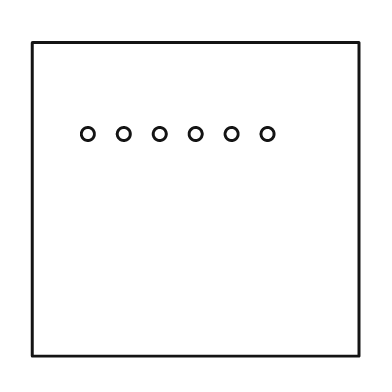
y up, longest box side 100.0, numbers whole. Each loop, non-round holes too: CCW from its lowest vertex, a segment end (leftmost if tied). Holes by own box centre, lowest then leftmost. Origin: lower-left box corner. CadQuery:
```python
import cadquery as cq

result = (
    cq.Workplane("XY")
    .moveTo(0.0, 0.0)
    .lineTo(100.0, 0.0)
    .lineTo(100.0, 96.0)
    .lineTo(0.0, 96.0)
    .close()
    .moveTo(17.0, 68.0)
    .circle(2.0)
    .moveTo(28.0, 68.0)
    .circle(2.0)
    .moveTo(39.0, 68.0)
    .circle(2.0)
    .moveTo(50.0, 68.0)
    .circle(2.0)
    .moveTo(61.0, 68.0)
    .circle(2.0)
    .moveTo(72.0, 68.0)
    .circle(2.0)
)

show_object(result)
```